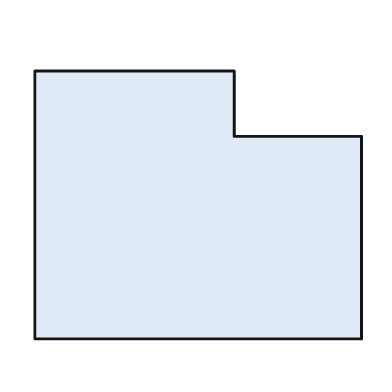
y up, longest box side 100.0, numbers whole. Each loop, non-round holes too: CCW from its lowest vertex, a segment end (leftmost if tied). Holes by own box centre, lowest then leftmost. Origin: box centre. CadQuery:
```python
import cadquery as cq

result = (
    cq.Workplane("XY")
    .moveTo(-50.0, -41.0)
    .lineTo(50.0, -41.0)
    .lineTo(50.0, 21.0)
    .lineTo(11.0, 21.0)
    .lineTo(11.0, 41.0)
    .lineTo(-50.0, 41.0)
    .close()
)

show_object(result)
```